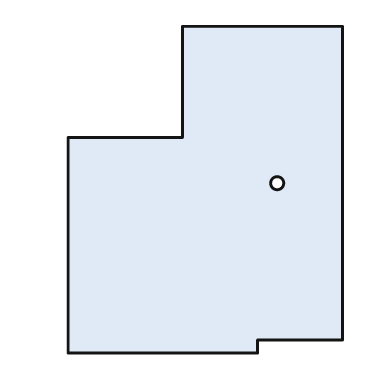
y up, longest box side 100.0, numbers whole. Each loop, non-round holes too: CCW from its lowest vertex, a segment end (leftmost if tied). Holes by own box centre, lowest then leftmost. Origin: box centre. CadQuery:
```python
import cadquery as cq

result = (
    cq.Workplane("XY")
    .moveTo(-42.0, -50.0)
    .lineTo(16.0, -50.0)
    .lineTo(16.0, -46.0)
    .lineTo(42.0, -46.0)
    .lineTo(42.0, 50.0)
    .lineTo(-7.0, 50.0)
    .lineTo(-7.0, 16.0)
    .lineTo(-42.0, 16.0)
    .close()
    .moveTo(22.0, 2.0)
    .circle(2.0)
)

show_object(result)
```